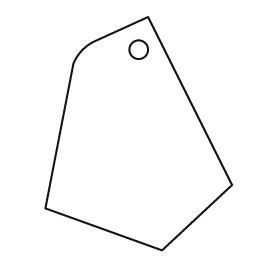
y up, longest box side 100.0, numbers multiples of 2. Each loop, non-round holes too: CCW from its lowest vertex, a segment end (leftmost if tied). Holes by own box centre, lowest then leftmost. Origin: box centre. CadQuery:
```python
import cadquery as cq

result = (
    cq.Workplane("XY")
    .moveTo(10.0, -50.0)
    .lineTo(40.0, -22.0)
    .lineTo(4.0, 50.0)
    .lineTo(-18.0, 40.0)
    .threePointArc((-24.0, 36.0), (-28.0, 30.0))
    .lineTo(-40.0, -32.0)
    .close()
    .moveTo(0.0, 36.0)
    .circle(4.0)
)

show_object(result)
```